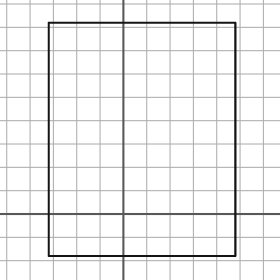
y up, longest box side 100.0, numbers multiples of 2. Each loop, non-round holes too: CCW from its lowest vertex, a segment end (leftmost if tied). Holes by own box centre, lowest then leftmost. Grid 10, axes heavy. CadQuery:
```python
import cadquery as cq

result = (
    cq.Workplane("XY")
    .moveTo(-32.0, -18.0)
    .lineTo(48.0, -18.0)
    .lineTo(48.0, 82.0)
    .lineTo(-32.0, 82.0)
    .close()
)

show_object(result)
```